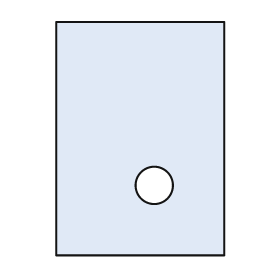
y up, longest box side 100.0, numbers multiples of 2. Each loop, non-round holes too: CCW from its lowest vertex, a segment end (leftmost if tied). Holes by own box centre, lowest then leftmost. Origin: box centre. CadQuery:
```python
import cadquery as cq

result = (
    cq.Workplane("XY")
    .moveTo(-36.0, -50.0)
    .lineTo(36.0, -50.0)
    .lineTo(36.0, 50.0)
    .lineTo(-36.0, 50.0)
    .close()
    .moveTo(6.0, -20.0)
    .circle(8.0)
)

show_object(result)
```